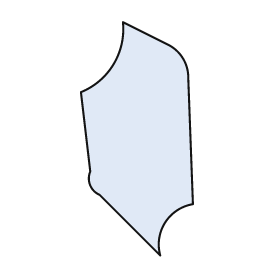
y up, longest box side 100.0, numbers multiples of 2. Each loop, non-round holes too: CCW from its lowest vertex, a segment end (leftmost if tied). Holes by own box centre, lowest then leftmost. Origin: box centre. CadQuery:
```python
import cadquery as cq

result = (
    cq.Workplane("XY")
    .moveTo(10.0, -50.0)
    .threePointArc((12.0, -36.0), (24.0, -28.0))
    .lineTo(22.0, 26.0)
    .threePointArc((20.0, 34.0), (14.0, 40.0))
    .lineTo(-6.0, 50.0)
    .threePointArc((-10.0, 32.0), (-24.0, 20.0))
    .lineTo(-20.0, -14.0)
    .threePointArc((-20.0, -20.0), (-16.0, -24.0))
    .close()
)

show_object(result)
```